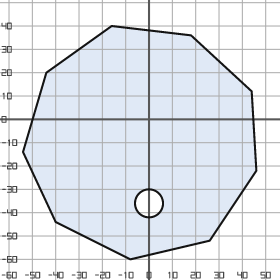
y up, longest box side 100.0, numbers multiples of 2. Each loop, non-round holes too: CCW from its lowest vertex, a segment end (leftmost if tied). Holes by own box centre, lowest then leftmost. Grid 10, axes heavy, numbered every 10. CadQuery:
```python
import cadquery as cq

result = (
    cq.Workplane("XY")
    .moveTo(-8.0, -60.0)
    .lineTo(26.0, -52.0)
    .lineTo(46.0, -22.0)
    .lineTo(44.0, 12.0)
    .lineTo(18.0, 36.0)
    .lineTo(-16.0, 40.0)
    .lineTo(-44.0, 20.0)
    .lineTo(-54.0, -14.0)
    .lineTo(-40.0, -44.0)
    .close()
    .moveTo(0.0, -36.0)
    .circle(6.0)
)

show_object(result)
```